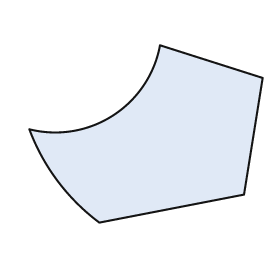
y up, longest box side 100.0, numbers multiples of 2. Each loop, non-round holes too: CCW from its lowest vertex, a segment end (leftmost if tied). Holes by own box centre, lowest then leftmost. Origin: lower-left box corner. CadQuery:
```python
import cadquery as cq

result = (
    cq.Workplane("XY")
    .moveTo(30.0, 0.0)
    .lineTo(92.0, 12.0)
    .lineTo(100.0, 62.0)
    .lineTo(56.0, 76.0)
    .threePointArc((36.0, 46.0), (0.0, 40.0))
    .threePointArc((12.0, 18.0), (30.0, 0.0))
    .close()
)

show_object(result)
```